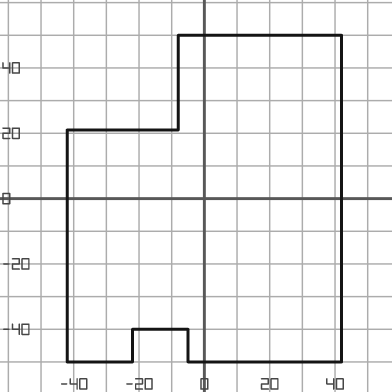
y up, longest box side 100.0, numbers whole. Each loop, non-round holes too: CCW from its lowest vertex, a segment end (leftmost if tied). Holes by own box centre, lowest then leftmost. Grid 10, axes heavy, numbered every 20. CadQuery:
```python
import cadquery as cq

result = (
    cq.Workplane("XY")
    .moveTo(-42.0, -50.0)
    .lineTo(-22.0, -50.0)
    .lineTo(-22.0, -40.0)
    .lineTo(-5.0, -40.0)
    .lineTo(-5.0, -50.0)
    .lineTo(42.0, -50.0)
    .lineTo(42.0, 50.0)
    .lineTo(-8.0, 50.0)
    .lineTo(-8.0, 21.0)
    .lineTo(-42.0, 21.0)
    .close()
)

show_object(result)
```